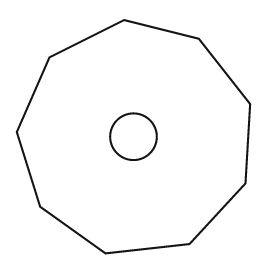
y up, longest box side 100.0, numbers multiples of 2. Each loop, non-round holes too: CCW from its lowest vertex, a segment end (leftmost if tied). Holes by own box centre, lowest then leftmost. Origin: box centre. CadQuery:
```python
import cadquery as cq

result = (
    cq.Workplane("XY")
    .moveTo(-12.0, -50.0)
    .lineTo(24.0, -46.0)
    .lineTo(48.0, -20.0)
    .lineTo(50.0, 14.0)
    .lineTo(28.0, 42.0)
    .lineTo(-4.0, 50.0)
    .lineTo(-36.0, 34.0)
    .lineTo(-50.0, 2.0)
    .lineTo(-40.0, -30.0)
    .close()
    .moveTo(0.0, 0.0)
    .circle(10.0)
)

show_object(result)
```